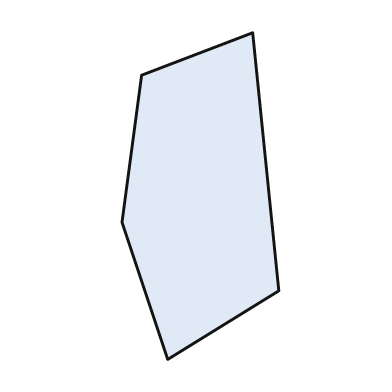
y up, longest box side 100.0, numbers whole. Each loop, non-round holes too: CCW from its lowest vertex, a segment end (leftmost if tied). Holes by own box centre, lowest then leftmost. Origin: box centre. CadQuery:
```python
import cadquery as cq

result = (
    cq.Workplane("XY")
    .moveTo(-10.0, -50.0)
    .lineTo(24.0, -29.0)
    .lineTo(16.0, 50.0)
    .lineTo(-18.0, 37.0)
    .lineTo(-24.0, -8.0)
    .close()
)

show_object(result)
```